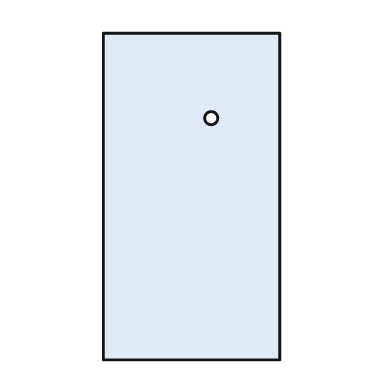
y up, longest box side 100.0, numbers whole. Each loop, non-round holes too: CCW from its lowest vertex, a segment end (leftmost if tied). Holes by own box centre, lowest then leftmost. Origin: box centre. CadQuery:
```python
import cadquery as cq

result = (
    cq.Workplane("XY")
    .moveTo(-27.0, -50.0)
    .lineTo(27.0, -50.0)
    .lineTo(27.0, 50.0)
    .lineTo(-27.0, 50.0)
    .close()
    .moveTo(6.0, 24.0)
    .circle(2.0)
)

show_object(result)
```